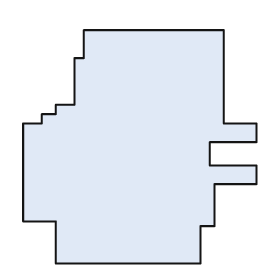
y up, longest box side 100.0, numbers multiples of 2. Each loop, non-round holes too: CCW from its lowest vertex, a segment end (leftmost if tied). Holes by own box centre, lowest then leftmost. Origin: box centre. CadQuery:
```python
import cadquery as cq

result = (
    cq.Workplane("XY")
    .moveTo(-36.0, -50.0)
    .lineTo(26.0, -50.0)
    .lineTo(26.0, -34.0)
    .lineTo(32.0, -34.0)
    .lineTo(32.0, -16.0)
    .lineTo(50.0, -16.0)
    .lineTo(50.0, -8.0)
    .lineTo(30.0, -8.0)
    .lineTo(30.0, 2.0)
    .lineTo(50.0, 2.0)
    .lineTo(50.0, 10.0)
    .lineTo(36.0, 10.0)
    .lineTo(36.0, 50.0)
    .lineTo(-24.0, 50.0)
    .lineTo(-24.0, 38.0)
    .lineTo(-28.0, 38.0)
    .lineTo(-28.0, 18.0)
    .lineTo(-36.0, 18.0)
    .lineTo(-36.0, 14.0)
    .lineTo(-42.0, 14.0)
    .lineTo(-42.0, 10.0)
    .lineTo(-50.0, 10.0)
    .lineTo(-50.0, -32.0)
    .lineTo(-36.0, -32.0)
    .close()
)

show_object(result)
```